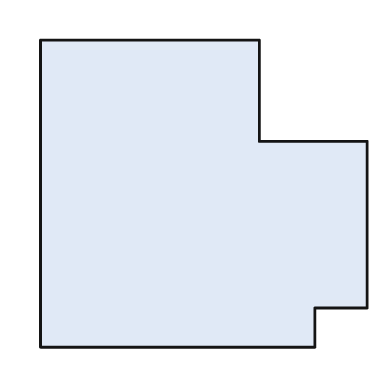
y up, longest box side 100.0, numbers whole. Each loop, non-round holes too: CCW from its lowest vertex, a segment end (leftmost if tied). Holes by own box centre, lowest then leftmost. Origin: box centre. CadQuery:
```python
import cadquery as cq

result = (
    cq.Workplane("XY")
    .moveTo(-50.0, -47.0)
    .lineTo(34.0, -47.0)
    .lineTo(34.0, -35.0)
    .lineTo(50.0, -35.0)
    .lineTo(50.0, 16.0)
    .lineTo(17.0, 16.0)
    .lineTo(17.0, 47.0)
    .lineTo(-50.0, 47.0)
    .close()
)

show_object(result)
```